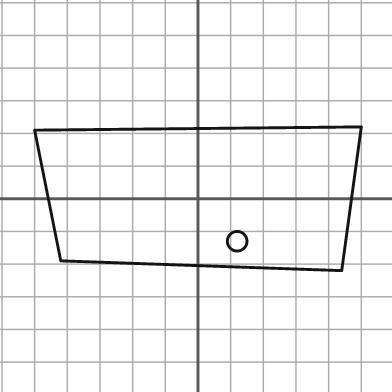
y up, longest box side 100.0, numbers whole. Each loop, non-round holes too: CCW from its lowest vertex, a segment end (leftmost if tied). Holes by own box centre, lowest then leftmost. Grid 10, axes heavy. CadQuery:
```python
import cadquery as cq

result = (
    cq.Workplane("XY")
    .moveTo(44.0, -22.0)
    .lineTo(50.0, 22.0)
    .lineTo(-50.0, 21.0)
    .lineTo(-42.0, -19.0)
    .close()
    .moveTo(12.0, -13.0)
    .circle(3.0)
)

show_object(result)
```